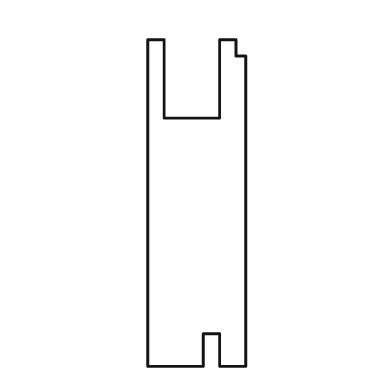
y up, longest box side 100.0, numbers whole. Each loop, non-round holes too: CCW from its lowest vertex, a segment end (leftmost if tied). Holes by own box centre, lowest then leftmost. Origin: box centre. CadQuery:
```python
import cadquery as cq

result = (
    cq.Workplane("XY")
    .moveTo(-15.0, -50.0)
    .lineTo(2.0, -50.0)
    .lineTo(2.0, -40.0)
    .lineTo(7.0, -40.0)
    .lineTo(7.0, -50.0)
    .lineTo(15.0, -50.0)
    .lineTo(15.0, 45.0)
    .lineTo(12.0, 45.0)
    .lineTo(12.0, 50.0)
    .lineTo(7.0, 50.0)
    .lineTo(7.0, 26.0)
    .lineTo(-10.0, 26.0)
    .lineTo(-10.0, 50.0)
    .lineTo(-15.0, 50.0)
    .close()
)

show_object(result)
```